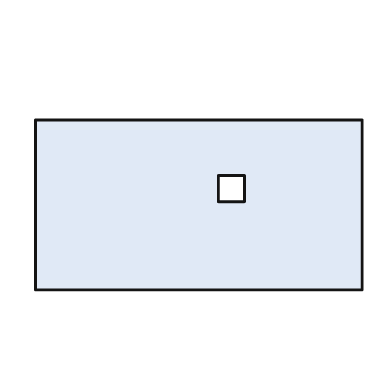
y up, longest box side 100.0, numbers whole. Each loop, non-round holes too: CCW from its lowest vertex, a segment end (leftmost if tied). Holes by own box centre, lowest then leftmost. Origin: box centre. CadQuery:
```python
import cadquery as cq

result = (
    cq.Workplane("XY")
    .moveTo(-50.0, -26.0)
    .lineTo(50.0, -26.0)
    .lineTo(50.0, 26.0)
    .lineTo(-50.0, 26.0)
    .close()
    .moveTo(6.0, 1.0)
    .lineTo(14.0, 1.0)
    .lineTo(14.0, 9.0)
    .lineTo(6.0, 9.0)
    .close()
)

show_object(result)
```